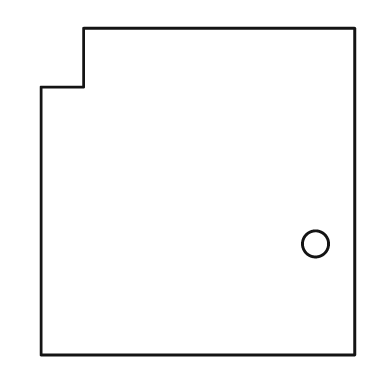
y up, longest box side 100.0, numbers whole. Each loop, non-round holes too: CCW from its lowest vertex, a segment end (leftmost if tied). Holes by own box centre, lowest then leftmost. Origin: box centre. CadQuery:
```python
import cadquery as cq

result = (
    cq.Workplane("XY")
    .moveTo(-48.0, -50.0)
    .lineTo(48.0, -50.0)
    .lineTo(48.0, 50.0)
    .lineTo(-35.0, 50.0)
    .lineTo(-35.0, 32.0)
    .lineTo(-48.0, 32.0)
    .close()
    .moveTo(36.0, -16.0)
    .circle(4.0)
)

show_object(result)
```